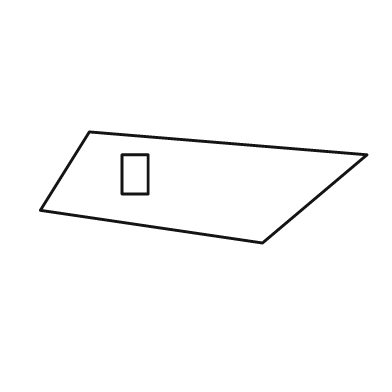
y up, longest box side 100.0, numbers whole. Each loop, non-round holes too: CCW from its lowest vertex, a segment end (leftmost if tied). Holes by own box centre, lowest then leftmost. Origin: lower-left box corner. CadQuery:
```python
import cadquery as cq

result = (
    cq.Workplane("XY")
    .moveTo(68.0, 0.0)
    .lineTo(100.0, 27.0)
    .lineTo(15.0, 34.0)
    .lineTo(0.0, 10.0)
    .close()
    .moveTo(25.0, 15.0)
    .lineTo(33.0, 15.0)
    .lineTo(33.0, 27.0)
    .lineTo(25.0, 27.0)
    .close()
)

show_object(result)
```